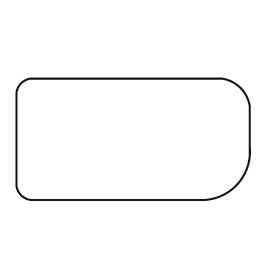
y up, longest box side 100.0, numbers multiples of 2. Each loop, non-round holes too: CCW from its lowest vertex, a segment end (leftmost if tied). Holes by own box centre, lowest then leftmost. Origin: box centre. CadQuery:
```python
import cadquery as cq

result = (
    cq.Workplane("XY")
    .moveTo(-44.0, -26.0)
    .lineTo(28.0, -26.0)
    .threePointArc((44.0, -20.0), (50.0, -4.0))
    .lineTo(50.0, 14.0)
    .threePointArc((46.0, 22.0), (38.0, 26.0))
    .lineTo(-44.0, 26.0)
    .threePointArc((-48.0, 24.0), (-50.0, 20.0))
    .lineTo(-50.0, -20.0)
    .threePointArc((-48.0, -24.0), (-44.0, -26.0))
    .close()
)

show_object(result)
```